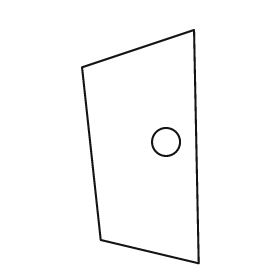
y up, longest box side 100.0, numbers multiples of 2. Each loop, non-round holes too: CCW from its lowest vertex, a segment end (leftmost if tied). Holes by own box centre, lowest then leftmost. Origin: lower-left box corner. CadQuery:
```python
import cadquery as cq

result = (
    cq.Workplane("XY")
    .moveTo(50.0, 0.0)
    .lineTo(48.0, 100.0)
    .lineTo(0.0, 84.0)
    .lineTo(8.0, 10.0)
    .close()
    .moveTo(36.0, 52.0)
    .circle(6.0)
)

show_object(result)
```